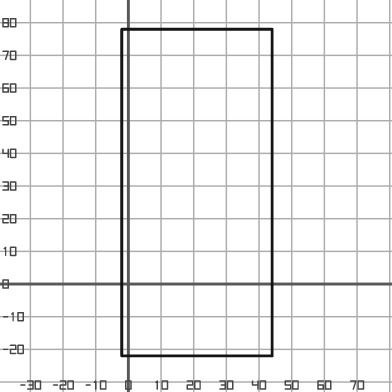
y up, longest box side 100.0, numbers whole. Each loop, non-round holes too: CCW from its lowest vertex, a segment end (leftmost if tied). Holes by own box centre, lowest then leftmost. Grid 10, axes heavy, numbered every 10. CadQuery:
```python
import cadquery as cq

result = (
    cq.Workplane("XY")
    .moveTo(-2.0, -22.0)
    .lineTo(44.0, -22.0)
    .lineTo(44.0, 78.0)
    .lineTo(-2.0, 78.0)
    .close()
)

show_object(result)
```